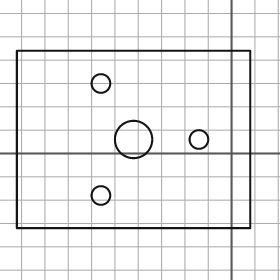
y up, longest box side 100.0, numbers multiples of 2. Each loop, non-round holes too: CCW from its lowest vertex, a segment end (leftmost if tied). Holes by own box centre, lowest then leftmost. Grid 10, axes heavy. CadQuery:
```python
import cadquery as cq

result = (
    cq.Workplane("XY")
    .moveTo(-92.0, -32.0)
    .lineTo(8.0, -32.0)
    .lineTo(8.0, 44.0)
    .lineTo(-92.0, 44.0)
    .close()
    .moveTo(-56.0, -18.0)
    .circle(4.0)
    .moveTo(-42.0, 6.0)
    .circle(8.0)
    .moveTo(-14.0, 6.0)
    .circle(4.0)
    .moveTo(-56.0, 30.0)
    .circle(4.0)
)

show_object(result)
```